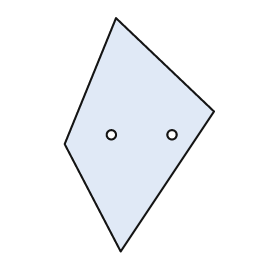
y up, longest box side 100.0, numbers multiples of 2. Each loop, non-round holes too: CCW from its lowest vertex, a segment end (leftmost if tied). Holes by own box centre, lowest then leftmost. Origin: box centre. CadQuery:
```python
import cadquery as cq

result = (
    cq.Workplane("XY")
    .moveTo(-8.0, -50.0)
    .lineTo(32.0, 10.0)
    .lineTo(-10.0, 50.0)
    .lineTo(-32.0, -4.0)
    .close()
    .moveTo(-12.0, 0.0)
    .circle(2.0)
    .moveTo(14.0, 0.0)
    .circle(2.0)
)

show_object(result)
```